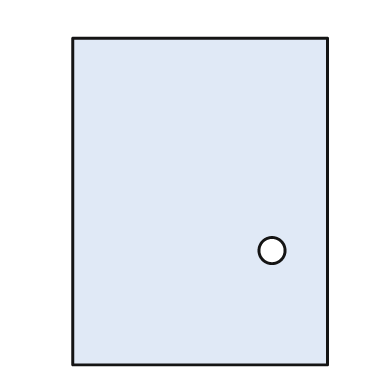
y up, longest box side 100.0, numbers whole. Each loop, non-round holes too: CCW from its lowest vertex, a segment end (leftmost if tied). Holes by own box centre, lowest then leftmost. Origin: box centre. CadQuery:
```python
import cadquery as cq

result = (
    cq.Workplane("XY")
    .moveTo(-39.0, -50.0)
    .lineTo(39.0, -50.0)
    .lineTo(39.0, 50.0)
    .lineTo(-39.0, 50.0)
    .close()
    .moveTo(22.0, -15.0)
    .circle(4.0)
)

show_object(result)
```